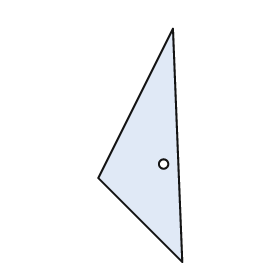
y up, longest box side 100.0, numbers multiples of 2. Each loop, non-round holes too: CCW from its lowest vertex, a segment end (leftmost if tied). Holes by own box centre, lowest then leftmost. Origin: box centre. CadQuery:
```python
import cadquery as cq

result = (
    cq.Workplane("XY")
    .moveTo(18.0, -50.0)
    .lineTo(14.0, 50.0)
    .lineTo(-18.0, -14.0)
    .close()
    .moveTo(10.0, -8.0)
    .circle(2.0)
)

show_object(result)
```